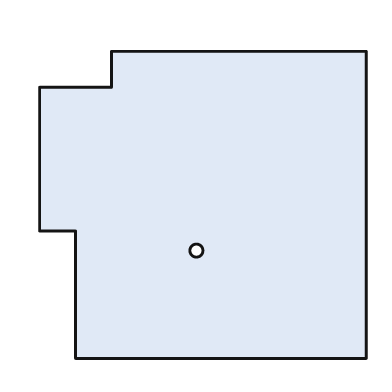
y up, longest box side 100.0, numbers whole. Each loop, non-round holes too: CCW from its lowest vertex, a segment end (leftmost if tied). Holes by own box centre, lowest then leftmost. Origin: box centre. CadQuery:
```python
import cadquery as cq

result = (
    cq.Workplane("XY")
    .moveTo(-39.0, -47.0)
    .lineTo(50.0, -47.0)
    .lineTo(50.0, 47.0)
    .lineTo(-28.0, 47.0)
    .lineTo(-28.0, 36.0)
    .lineTo(-50.0, 36.0)
    .lineTo(-50.0, -8.0)
    .lineTo(-39.0, -8.0)
    .close()
    .moveTo(-2.0, -14.0)
    .circle(2.0)
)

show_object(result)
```